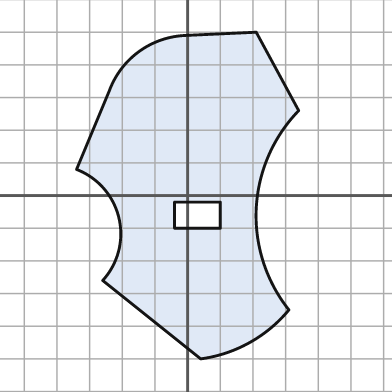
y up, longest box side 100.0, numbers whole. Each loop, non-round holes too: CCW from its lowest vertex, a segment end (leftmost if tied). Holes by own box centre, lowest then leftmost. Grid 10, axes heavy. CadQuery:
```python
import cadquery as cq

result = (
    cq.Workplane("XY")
    .moveTo(4.0, -50.0)
    .threePointArc((19.0, -45.0), (31.0, -35.0))
    .threePointArc((21.0, -4.0), (34.0, 26.0))
    .lineTo(21.0, 50.0)
    .lineTo(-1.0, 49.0)
    .threePointArc((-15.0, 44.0), (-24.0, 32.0))
    .lineTo(-34.0, 8.0)
    .threePointArc((-21.0, -7.0), (-26.0, -26.0))
    .close()
    .moveTo(-4.0, -10.0)
    .lineTo(10.0, -10.0)
    .lineTo(10.0, -2.0)
    .lineTo(-4.0, -2.0)
    .close()
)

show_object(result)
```